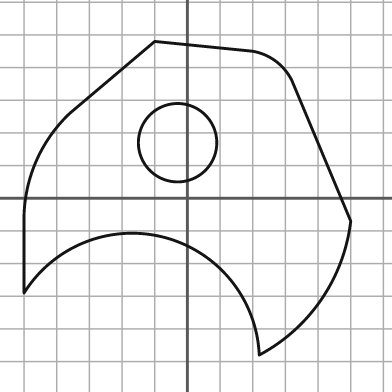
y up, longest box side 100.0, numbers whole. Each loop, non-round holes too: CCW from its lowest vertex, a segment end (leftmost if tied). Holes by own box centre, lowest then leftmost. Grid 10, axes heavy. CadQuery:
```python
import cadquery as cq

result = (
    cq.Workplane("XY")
    .moveTo(22.0, -48.0)
    .threePointArc((41.0, -31.0), (50.0, -7.0))
    .lineTo(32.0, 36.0)
    .threePointArc((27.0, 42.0), (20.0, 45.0))
    .lineTo(-10.0, 48.0)
    .lineTo(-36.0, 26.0)
    .threePointArc((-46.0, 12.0), (-50.0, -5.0))
    .lineTo(-50.0, -29.0)
    .threePointArc((-7.0, -12.0), (22.0, -48.0))
    .close()
    .moveTo(-3.0, 17.0)
    .circle(12.0)
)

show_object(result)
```